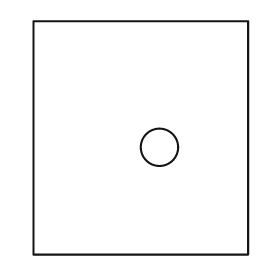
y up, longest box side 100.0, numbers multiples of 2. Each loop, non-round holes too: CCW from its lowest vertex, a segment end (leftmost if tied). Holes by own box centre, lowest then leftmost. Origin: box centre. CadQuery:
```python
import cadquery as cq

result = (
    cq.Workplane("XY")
    .moveTo(-46.0, -50.0)
    .lineTo(46.0, -50.0)
    .lineTo(46.0, 50.0)
    .lineTo(-46.0, 50.0)
    .close()
    .moveTo(8.0, -4.0)
    .circle(8.0)
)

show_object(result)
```